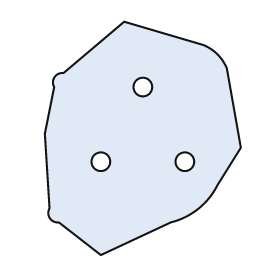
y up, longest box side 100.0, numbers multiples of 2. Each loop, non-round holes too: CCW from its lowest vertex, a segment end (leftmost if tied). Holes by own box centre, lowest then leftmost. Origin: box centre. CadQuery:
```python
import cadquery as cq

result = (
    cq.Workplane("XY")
    .moveTo(-18.0, -50.0)
    .lineTo(12.0, -36.0)
    .threePointArc((24.0, -30.0), (32.0, -20.0))
    .lineTo(42.0, -4.0)
    .lineTo(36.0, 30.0)
    .threePointArc((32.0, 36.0), (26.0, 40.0))
    .lineTo(-8.0, 50.0)
    .lineTo(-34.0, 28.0)
    .threePointArc((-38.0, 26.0), (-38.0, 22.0))
    .lineTo(-42.0, 2.0)
    .lineTo(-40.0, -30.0)
    .threePointArc((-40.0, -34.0), (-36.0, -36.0))
    .close()
    .moveTo(-18.0, -10.0)
    .circle(4.0)
    .moveTo(18.0, -10.0)
    .circle(4.0)
    .moveTo(0.0, 22.0)
    .circle(4.0)
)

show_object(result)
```